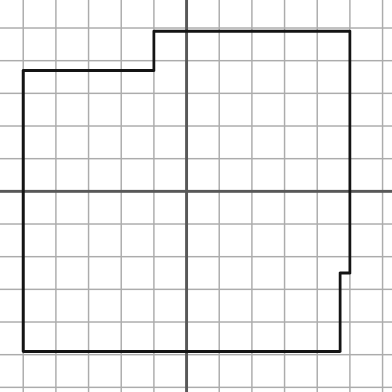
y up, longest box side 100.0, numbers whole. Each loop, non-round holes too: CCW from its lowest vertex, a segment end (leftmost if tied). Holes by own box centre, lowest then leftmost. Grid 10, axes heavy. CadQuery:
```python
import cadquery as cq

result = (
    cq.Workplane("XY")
    .moveTo(-50.0, -49.0)
    .lineTo(47.0, -49.0)
    .lineTo(47.0, -25.0)
    .lineTo(50.0, -25.0)
    .lineTo(50.0, 49.0)
    .lineTo(-10.0, 49.0)
    .lineTo(-10.0, 37.0)
    .lineTo(-50.0, 37.0)
    .close()
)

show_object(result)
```